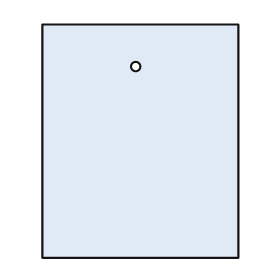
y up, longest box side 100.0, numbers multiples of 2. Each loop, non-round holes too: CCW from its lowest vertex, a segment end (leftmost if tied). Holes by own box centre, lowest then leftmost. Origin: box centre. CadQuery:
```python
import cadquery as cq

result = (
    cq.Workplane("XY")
    .moveTo(-42.0, -50.0)
    .lineTo(42.0, -50.0)
    .lineTo(42.0, 50.0)
    .lineTo(-42.0, 50.0)
    .close()
    .moveTo(-2.0, 32.0)
    .circle(2.0)
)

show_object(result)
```